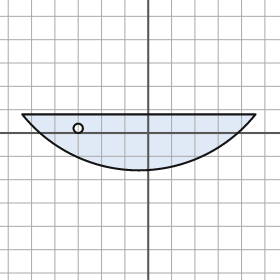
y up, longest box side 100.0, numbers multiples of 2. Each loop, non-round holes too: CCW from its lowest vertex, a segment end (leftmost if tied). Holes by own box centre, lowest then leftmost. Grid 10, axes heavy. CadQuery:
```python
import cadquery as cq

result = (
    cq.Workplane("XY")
    .moveTo(-54.0, 8.0)
    .threePointArc((-4.0, -16.0), (46.0, 8.0))
    .close()
    .moveTo(-30.0, 2.0)
    .circle(2.0)
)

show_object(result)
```